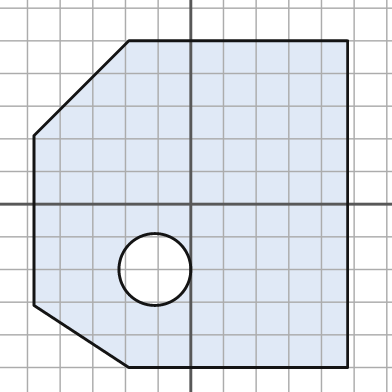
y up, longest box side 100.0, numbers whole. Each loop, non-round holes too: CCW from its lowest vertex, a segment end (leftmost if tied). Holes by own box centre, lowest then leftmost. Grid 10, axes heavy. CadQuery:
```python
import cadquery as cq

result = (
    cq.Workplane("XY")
    .moveTo(-19.0, -50.0)
    .lineTo(48.0, -50.0)
    .lineTo(48.0, 50.0)
    .lineTo(-19.0, 50.0)
    .lineTo(-48.0, 21.0)
    .lineTo(-48.0, -31.0)
    .close()
    .moveTo(-11.0, -20.0)
    .circle(11.0)
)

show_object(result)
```